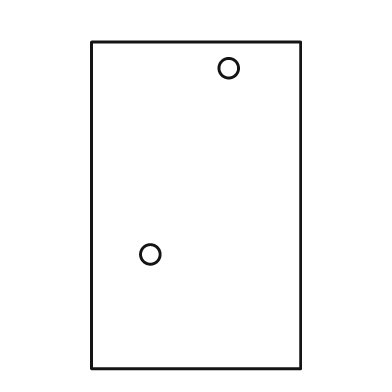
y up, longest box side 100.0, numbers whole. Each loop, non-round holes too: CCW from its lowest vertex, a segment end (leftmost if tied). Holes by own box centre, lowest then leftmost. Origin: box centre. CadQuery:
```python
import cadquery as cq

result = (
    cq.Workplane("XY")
    .moveTo(-32.0, -50.0)
    .lineTo(32.0, -50.0)
    .lineTo(32.0, 50.0)
    .lineTo(-32.0, 50.0)
    .close()
    .moveTo(-14.0, -15.0)
    .circle(3.0)
    .moveTo(10.0, 42.0)
    .circle(3.0)
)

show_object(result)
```